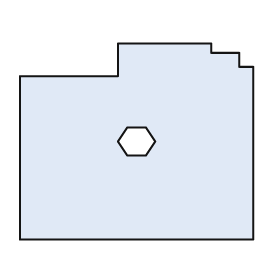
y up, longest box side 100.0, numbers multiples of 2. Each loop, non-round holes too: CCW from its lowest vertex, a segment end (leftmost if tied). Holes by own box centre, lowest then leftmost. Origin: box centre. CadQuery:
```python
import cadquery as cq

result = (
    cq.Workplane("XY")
    .moveTo(-50.0, -42.0)
    .lineTo(50.0, -42.0)
    .lineTo(50.0, 32.0)
    .lineTo(44.0, 32.0)
    .lineTo(44.0, 38.0)
    .lineTo(32.0, 38.0)
    .lineTo(32.0, 42.0)
    .lineTo(-8.0, 42.0)
    .lineTo(-8.0, 28.0)
    .lineTo(-50.0, 28.0)
    .close()
    .moveTo(-4.0, -6.0)
    .lineTo(4.0, -6.0)
    .lineTo(8.0, 0.0)
    .lineTo(4.0, 6.0)
    .lineTo(-4.0, 6.0)
    .lineTo(-8.0, 0.0)
    .close()
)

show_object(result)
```